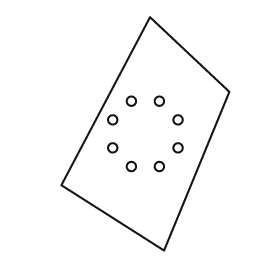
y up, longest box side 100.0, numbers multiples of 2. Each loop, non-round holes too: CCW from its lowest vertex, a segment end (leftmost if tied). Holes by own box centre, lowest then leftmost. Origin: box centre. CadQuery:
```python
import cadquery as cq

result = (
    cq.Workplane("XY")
    .moveTo(8.0, -50.0)
    .lineTo(36.0, 18.0)
    .lineTo(2.0, 50.0)
    .lineTo(-36.0, -22.0)
    .close()
    .moveTo(-6.0, -14.0)
    .circle(2.0)
    .moveTo(6.0, -14.0)
    .circle(2.0)
    .moveTo(-14.0, -6.0)
    .circle(2.0)
    .moveTo(14.0, -6.0)
    .circle(2.0)
    .moveTo(-14.0, 6.0)
    .circle(2.0)
    .moveTo(14.0, 6.0)
    .circle(2.0)
    .moveTo(-6.0, 14.0)
    .circle(2.0)
    .moveTo(6.0, 14.0)
    .circle(2.0)
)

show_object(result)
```